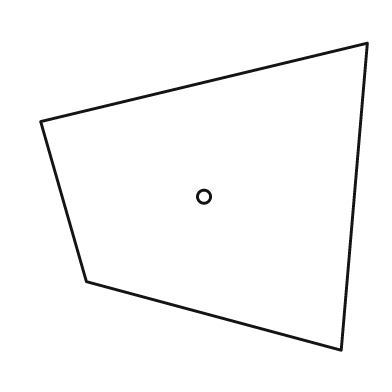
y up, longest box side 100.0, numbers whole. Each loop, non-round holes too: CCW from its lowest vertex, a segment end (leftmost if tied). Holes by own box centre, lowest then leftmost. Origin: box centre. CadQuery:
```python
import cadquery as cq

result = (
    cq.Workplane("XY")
    .moveTo(42.0, -47.0)
    .lineTo(50.0, 47.0)
    .lineTo(-50.0, 23.0)
    .lineTo(-36.0, -26.0)
    .close()
    .moveTo(0.0, 0.0)
    .circle(2.0)
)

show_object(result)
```